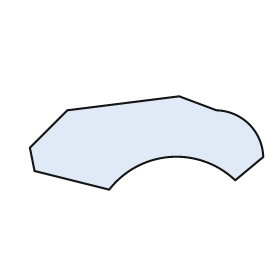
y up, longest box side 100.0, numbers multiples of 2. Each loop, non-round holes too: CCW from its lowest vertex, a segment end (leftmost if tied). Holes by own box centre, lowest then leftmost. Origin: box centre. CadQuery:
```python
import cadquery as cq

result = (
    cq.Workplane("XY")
    .moveTo(-16.0, -20.0)
    .threePointArc((10.0, -6.0), (38.0, -16.0))
    .lineTo(50.0, -6.0)
    .threePointArc((44.0, 8.0), (30.0, 14.0))
    .lineTo(14.0, 20.0)
    .lineTo(-34.0, 14.0)
    .lineTo(-50.0, -2.0)
    .lineTo(-48.0, -12.0)
    .close()
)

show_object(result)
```